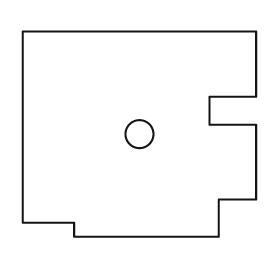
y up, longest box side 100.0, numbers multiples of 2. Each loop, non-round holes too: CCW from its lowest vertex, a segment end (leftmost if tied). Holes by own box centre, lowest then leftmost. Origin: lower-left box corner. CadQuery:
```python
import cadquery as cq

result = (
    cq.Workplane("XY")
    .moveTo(22.0, 0.0)
    .lineTo(84.0, 0.0)
    .lineTo(84.0, 16.0)
    .lineTo(100.0, 16.0)
    .lineTo(100.0, 48.0)
    .lineTo(80.0, 48.0)
    .lineTo(80.0, 60.0)
    .lineTo(100.0, 60.0)
    .lineTo(100.0, 88.0)
    .lineTo(0.0, 88.0)
    .lineTo(0.0, 6.0)
    .lineTo(22.0, 6.0)
    .close()
    .moveTo(50.0, 44.0)
    .circle(6.0)
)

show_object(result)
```